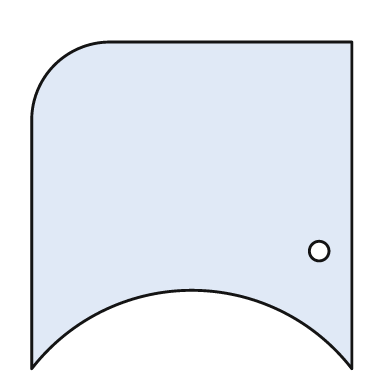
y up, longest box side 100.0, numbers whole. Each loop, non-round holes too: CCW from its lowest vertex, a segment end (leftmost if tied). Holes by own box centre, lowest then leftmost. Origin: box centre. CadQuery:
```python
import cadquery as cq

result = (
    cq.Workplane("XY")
    .moveTo(-49.0, -50.0)
    .threePointArc((0.0, -26.0), (49.0, -50.0))
    .lineTo(49.0, 50.0)
    .lineTo(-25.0, 50.0)
    .threePointArc((-42.0, 43.0), (-49.0, 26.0))
    .close()
    .moveTo(39.0, -14.0)
    .circle(3.0)
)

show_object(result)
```